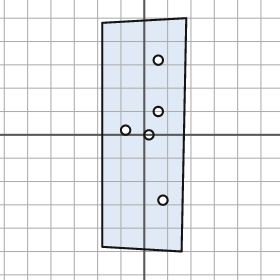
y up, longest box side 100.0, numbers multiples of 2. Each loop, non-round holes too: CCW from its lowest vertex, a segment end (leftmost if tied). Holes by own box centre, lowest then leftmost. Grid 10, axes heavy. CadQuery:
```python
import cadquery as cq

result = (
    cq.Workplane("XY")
    .moveTo(16.0, -50.0)
    .lineTo(18.0, 50.0)
    .lineTo(-18.0, 48.0)
    .lineTo(-18.0, -48.0)
    .close()
    .moveTo(8.0, -28.0)
    .circle(2.0)
    .moveTo(2.0, 0.0)
    .circle(2.0)
    .moveTo(-8.0, 2.0)
    .circle(2.0)
    .moveTo(6.0, 10.0)
    .circle(2.0)
    .moveTo(6.0, 32.0)
    .circle(2.0)
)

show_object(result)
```